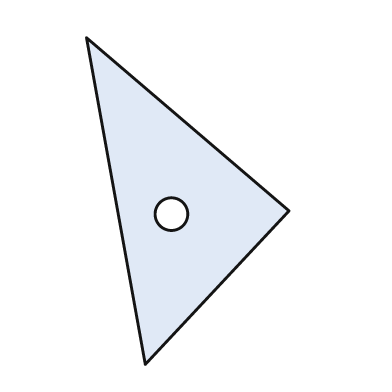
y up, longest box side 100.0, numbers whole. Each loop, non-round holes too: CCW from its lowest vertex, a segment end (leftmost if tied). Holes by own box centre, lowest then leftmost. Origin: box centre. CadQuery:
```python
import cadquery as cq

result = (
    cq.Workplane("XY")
    .moveTo(-13.0, -50.0)
    .lineTo(31.0, -3.0)
    .lineTo(-31.0, 50.0)
    .close()
    .moveTo(-5.0, -4.0)
    .circle(5.0)
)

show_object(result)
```